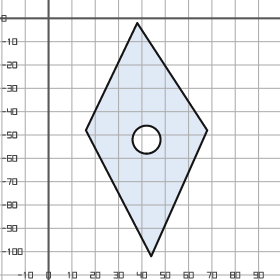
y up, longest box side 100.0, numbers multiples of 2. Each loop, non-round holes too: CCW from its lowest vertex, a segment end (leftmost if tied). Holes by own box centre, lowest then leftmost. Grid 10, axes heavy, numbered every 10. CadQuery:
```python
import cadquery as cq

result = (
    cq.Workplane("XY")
    .moveTo(44.0, -102.0)
    .lineTo(68.0, -48.0)
    .lineTo(38.0, -2.0)
    .lineTo(16.0, -48.0)
    .close()
    .moveTo(42.0, -52.0)
    .circle(6.0)
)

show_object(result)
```